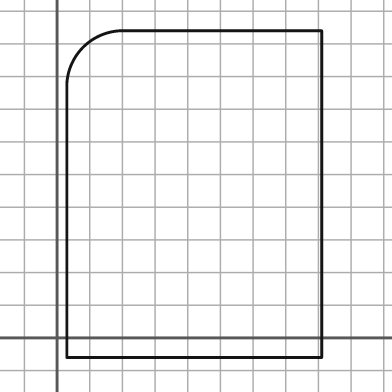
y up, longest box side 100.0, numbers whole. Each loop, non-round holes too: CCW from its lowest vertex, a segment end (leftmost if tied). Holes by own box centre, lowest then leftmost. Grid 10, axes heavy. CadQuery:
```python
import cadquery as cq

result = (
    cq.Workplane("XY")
    .moveTo(3.0, -6.0)
    .lineTo(81.0, -6.0)
    .lineTo(81.0, 94.0)
    .lineTo(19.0, 94.0)
    .threePointArc((8.0, 89.0), (3.0, 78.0))
    .close()
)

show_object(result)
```